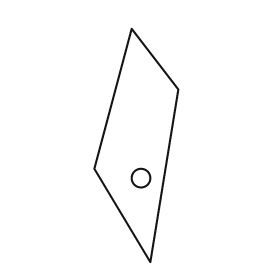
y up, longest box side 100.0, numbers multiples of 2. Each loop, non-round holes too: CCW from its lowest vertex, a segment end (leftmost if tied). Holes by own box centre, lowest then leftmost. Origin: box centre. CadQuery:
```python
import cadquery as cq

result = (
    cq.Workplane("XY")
    .moveTo(6.0, -50.0)
    .lineTo(18.0, 24.0)
    .lineTo(-2.0, 50.0)
    .lineTo(-18.0, -10.0)
    .close()
    .moveTo(2.0, -14.0)
    .circle(4.0)
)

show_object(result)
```